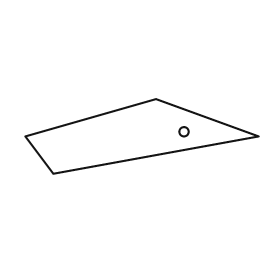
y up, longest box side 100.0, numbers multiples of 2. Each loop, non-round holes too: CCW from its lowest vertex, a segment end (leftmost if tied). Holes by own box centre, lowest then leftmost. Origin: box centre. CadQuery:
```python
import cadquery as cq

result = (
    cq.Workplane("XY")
    .moveTo(-38.0, -16.0)
    .lineTo(50.0, 0.0)
    .lineTo(6.0, 16.0)
    .lineTo(-50.0, 0.0)
    .close()
    .moveTo(18.0, 2.0)
    .circle(2.0)
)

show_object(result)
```